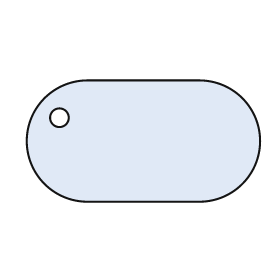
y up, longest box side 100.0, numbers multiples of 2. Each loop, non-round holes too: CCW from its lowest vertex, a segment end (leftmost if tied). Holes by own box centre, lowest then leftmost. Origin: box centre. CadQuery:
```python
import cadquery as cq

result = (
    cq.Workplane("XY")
    .moveTo(-24.0, -26.0)
    .lineTo(24.0, -26.0)
    .threePointArc((50.0, 0.0), (24.0, 26.0))
    .lineTo(-24.0, 26.0)
    .threePointArc((-50.0, 0.0), (-24.0, -26.0))
    .close()
    .moveTo(-36.0, 10.0)
    .circle(4.0)
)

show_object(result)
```